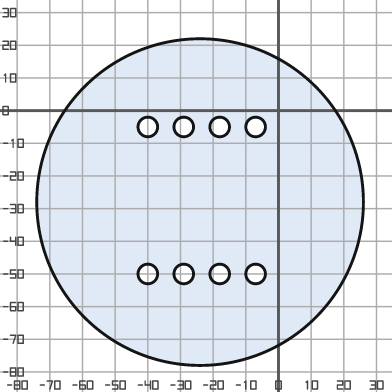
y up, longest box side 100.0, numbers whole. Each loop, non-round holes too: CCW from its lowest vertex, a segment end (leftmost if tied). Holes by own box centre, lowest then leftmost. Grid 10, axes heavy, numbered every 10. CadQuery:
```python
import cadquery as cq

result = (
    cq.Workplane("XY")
    .moveTo(-24.0, -28.0)
    .circle(50.0)
    .moveTo(-40.0, -50.0)
    .circle(3.0)
    .moveTo(-29.0, -50.0)
    .circle(3.0)
    .moveTo(-18.0, -50.0)
    .circle(3.0)
    .moveTo(-7.0, -50.0)
    .circle(3.0)
    .moveTo(-40.0, -5.0)
    .circle(3.0)
    .moveTo(-29.0, -5.0)
    .circle(3.0)
    .moveTo(-18.0, -5.0)
    .circle(3.0)
    .moveTo(-7.0, -5.0)
    .circle(3.0)
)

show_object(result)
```